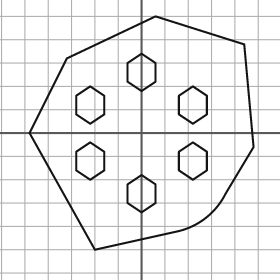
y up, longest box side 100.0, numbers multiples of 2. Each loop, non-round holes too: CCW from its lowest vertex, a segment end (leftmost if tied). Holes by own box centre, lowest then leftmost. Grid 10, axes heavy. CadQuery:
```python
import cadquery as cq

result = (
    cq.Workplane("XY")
    .moveTo(-20.0, -50.0)
    .lineTo(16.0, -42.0)
    .threePointArc((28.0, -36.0), (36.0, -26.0))
    .lineTo(48.0, -6.0)
    .lineTo(44.0, 38.0)
    .lineTo(6.0, 50.0)
    .lineTo(-32.0, 32.0)
    .lineTo(-48.0, 0.0)
    .close()
    .moveTo(0.0, -34.0)
    .lineTo(6.0, -30.0)
    .lineTo(6.0, -22.0)
    .lineTo(0.0, -18.0)
    .lineTo(-6.0, -22.0)
    .lineTo(-6.0, -30.0)
    .close()
    .moveTo(-22.0, -20.0)
    .lineTo(-16.0, -16.0)
    .lineTo(-16.0, -8.0)
    .lineTo(-22.0, -4.0)
    .lineTo(-28.0, -8.0)
    .lineTo(-28.0, -16.0)
    .close()
    .moveTo(22.0, -20.0)
    .lineTo(28.0, -16.0)
    .lineTo(28.0, -8.0)
    .lineTo(22.0, -4.0)
    .lineTo(16.0, -8.0)
    .lineTo(16.0, -16.0)
    .close()
    .moveTo(-22.0, 4.0)
    .lineTo(-16.0, 8.0)
    .lineTo(-16.0, 16.0)
    .lineTo(-22.0, 20.0)
    .lineTo(-28.0, 16.0)
    .lineTo(-28.0, 8.0)
    .close()
    .moveTo(22.0, 4.0)
    .lineTo(28.0, 8.0)
    .lineTo(28.0, 16.0)
    .lineTo(22.0, 20.0)
    .lineTo(16.0, 16.0)
    .lineTo(16.0, 8.0)
    .close()
    .moveTo(0.0, 18.0)
    .lineTo(6.0, 22.0)
    .lineTo(6.0, 30.0)
    .lineTo(0.0, 34.0)
    .lineTo(-6.0, 30.0)
    .lineTo(-6.0, 22.0)
    .close()
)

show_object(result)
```